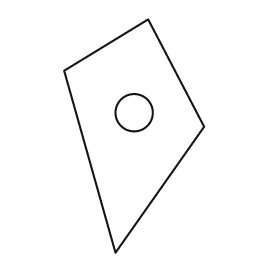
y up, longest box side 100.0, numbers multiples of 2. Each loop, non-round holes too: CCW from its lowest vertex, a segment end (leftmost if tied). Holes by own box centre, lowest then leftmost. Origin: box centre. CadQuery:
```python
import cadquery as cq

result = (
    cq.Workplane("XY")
    .moveTo(-8.0, -50.0)
    .lineTo(30.0, 4.0)
    .lineTo(6.0, 50.0)
    .lineTo(-30.0, 28.0)
    .close()
    .moveTo(0.0, 10.0)
    .circle(8.0)
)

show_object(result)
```